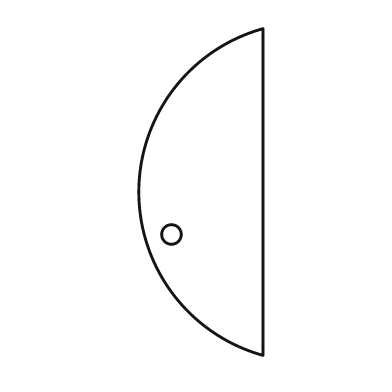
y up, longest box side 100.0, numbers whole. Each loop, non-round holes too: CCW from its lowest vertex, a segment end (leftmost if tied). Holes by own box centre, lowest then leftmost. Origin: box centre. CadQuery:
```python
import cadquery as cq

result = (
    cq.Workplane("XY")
    .moveTo(19.0, -50.0)
    .lineTo(19.0, 50.0)
    .threePointArc((-19.0, 0.0), (19.0, -50.0))
    .close()
    .moveTo(-9.0, -13.0)
    .circle(3.0)
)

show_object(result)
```